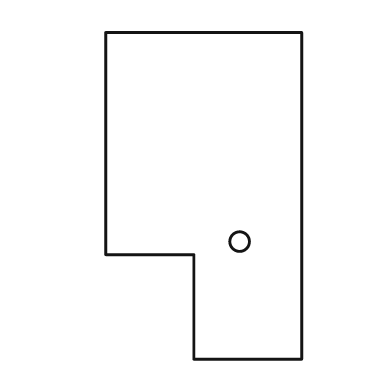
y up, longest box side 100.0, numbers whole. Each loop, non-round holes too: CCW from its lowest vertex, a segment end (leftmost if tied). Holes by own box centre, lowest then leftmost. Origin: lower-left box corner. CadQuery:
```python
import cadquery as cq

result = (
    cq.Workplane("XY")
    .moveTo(27.0, 0.0)
    .lineTo(60.0, 0.0)
    .lineTo(60.0, 100.0)
    .lineTo(0.0, 100.0)
    .lineTo(0.0, 32.0)
    .lineTo(27.0, 32.0)
    .close()
    .moveTo(41.0, 36.0)
    .circle(3.0)
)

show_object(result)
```